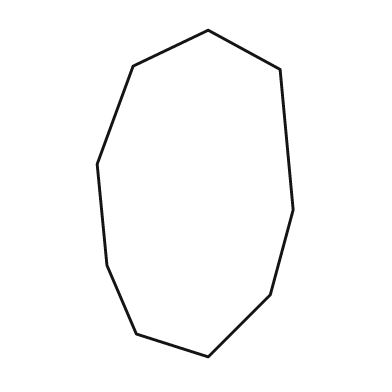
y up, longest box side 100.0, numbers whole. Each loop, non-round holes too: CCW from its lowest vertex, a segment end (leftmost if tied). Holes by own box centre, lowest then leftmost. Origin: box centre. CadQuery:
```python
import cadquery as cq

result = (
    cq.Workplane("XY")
    .moveTo(4.0, -50.0)
    .lineTo(23.0, -31.0)
    .lineTo(30.0, -5.0)
    .lineTo(26.0, 38.0)
    .lineTo(4.0, 50.0)
    .lineTo(-19.0, 39.0)
    .lineTo(-30.0, 9.0)
    .lineTo(-27.0, -22.0)
    .lineTo(-18.0, -43.0)
    .close()
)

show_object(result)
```